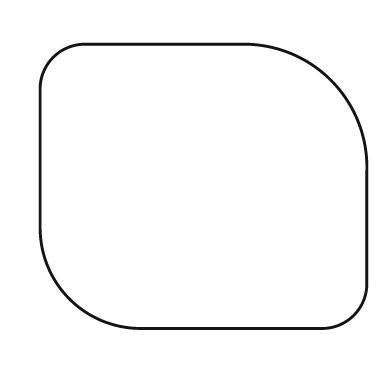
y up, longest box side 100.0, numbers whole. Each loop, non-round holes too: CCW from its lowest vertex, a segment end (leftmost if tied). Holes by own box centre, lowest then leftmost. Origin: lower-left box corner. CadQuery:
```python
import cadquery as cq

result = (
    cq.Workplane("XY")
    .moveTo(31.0, 0.0)
    .lineTo(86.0, 0.0)
    .threePointArc((96.0, 4.0), (100.0, 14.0))
    .lineTo(100.0, 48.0)
    .threePointArc((89.0, 76.0), (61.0, 87.0))
    .lineTo(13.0, 87.0)
    .threePointArc((4.0, 83.0), (0.0, 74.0))
    .lineTo(0.0, 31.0)
    .threePointArc((9.0, 9.0), (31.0, 0.0))
    .close()
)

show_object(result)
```